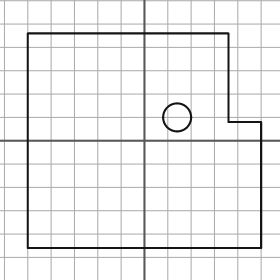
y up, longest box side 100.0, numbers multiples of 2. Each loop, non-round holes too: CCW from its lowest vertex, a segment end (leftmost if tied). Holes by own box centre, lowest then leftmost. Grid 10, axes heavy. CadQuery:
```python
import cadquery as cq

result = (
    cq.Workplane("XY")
    .moveTo(-50.0, -46.0)
    .lineTo(50.0, -46.0)
    .lineTo(50.0, 8.0)
    .lineTo(36.0, 8.0)
    .lineTo(36.0, 46.0)
    .lineTo(-50.0, 46.0)
    .close()
    .moveTo(14.0, 10.0)
    .circle(6.0)
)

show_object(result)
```